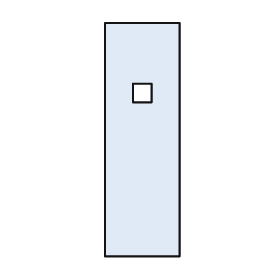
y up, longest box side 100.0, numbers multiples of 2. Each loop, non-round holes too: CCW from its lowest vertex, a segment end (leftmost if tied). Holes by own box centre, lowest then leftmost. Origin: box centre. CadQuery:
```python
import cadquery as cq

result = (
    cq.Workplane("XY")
    .moveTo(-16.0, -50.0)
    .lineTo(16.0, -50.0)
    .lineTo(16.0, 50.0)
    .lineTo(-16.0, 50.0)
    .close()
    .moveTo(-4.0, 16.0)
    .lineTo(4.0, 16.0)
    .lineTo(4.0, 24.0)
    .lineTo(-4.0, 24.0)
    .close()
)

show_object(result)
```